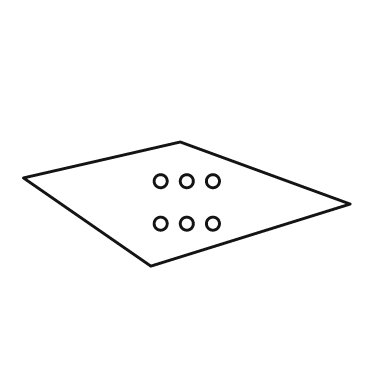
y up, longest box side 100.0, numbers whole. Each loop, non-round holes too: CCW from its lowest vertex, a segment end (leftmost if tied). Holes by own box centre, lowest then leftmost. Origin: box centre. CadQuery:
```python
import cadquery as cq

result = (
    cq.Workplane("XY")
    .moveTo(-11.0, -19.0)
    .lineTo(50.0, 0.0)
    .lineTo(-2.0, 19.0)
    .lineTo(-50.0, 8.0)
    .close()
    .moveTo(-8.0, -6.0)
    .circle(2.0)
    .moveTo(0.0, -6.0)
    .circle(2.0)
    .moveTo(8.0, -6.0)
    .circle(2.0)
    .moveTo(-8.0, 7.0)
    .circle(2.0)
    .moveTo(0.0, 7.0)
    .circle(2.0)
    .moveTo(8.0, 7.0)
    .circle(2.0)
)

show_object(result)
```